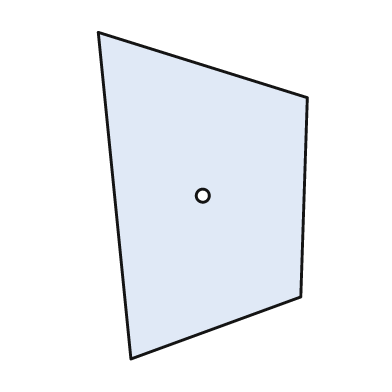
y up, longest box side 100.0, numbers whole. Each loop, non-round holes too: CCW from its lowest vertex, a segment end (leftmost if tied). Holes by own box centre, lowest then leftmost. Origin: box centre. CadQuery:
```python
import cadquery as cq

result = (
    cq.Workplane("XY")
    .moveTo(-22.0, -50.0)
    .lineTo(30.0, -31.0)
    .lineTo(32.0, 30.0)
    .lineTo(-32.0, 50.0)
    .close()
    .moveTo(0.0, 0.0)
    .circle(2.0)
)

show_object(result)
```